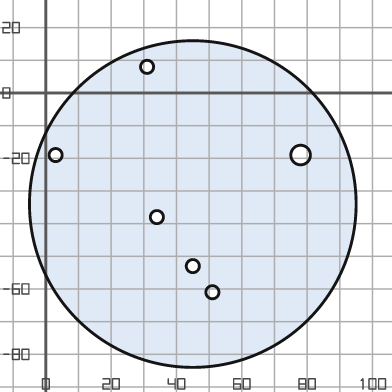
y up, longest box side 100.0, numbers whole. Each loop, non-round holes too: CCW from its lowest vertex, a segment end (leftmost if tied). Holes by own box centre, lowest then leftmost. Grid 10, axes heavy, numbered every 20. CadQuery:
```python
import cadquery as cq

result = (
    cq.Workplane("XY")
    .moveTo(45.0, -34.0)
    .circle(50.0)
    .moveTo(51.0, -61.0)
    .circle(2.0)
    .moveTo(45.0, -53.0)
    .circle(2.0)
    .moveTo(34.0, -38.0)
    .circle(2.0)
    .moveTo(3.0, -19.0)
    .circle(2.0)
    .moveTo(78.0, -19.0)
    .circle(3.0)
    .moveTo(31.0, 8.0)
    .circle(2.0)
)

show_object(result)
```